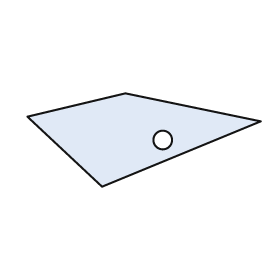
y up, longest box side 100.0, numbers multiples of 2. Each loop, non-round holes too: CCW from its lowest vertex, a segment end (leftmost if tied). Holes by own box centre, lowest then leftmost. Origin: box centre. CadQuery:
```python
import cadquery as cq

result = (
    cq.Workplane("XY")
    .moveTo(-18.0, -20.0)
    .lineTo(50.0, 8.0)
    .lineTo(-8.0, 20.0)
    .lineTo(-50.0, 10.0)
    .close()
    .moveTo(8.0, 0.0)
    .circle(4.0)
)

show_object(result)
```